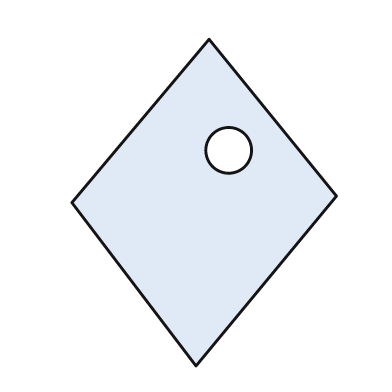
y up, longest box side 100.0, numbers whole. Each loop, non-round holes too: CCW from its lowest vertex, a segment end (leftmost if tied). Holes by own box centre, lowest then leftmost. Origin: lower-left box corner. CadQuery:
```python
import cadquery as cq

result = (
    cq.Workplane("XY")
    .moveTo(38.0, 0.0)
    .lineTo(81.0, 52.0)
    .lineTo(42.0, 100.0)
    .lineTo(0.0, 50.0)
    .close()
    .moveTo(48.0, 66.0)
    .circle(7.0)
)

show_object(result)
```